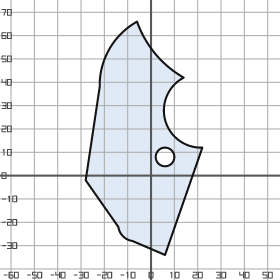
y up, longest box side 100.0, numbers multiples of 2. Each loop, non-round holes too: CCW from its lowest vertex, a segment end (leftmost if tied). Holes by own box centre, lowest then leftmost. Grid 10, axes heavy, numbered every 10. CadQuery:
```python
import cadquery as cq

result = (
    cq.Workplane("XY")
    .moveTo(6.0, -34.0)
    .lineTo(22.0, 12.0)
    .threePointArc((6.0, 24.0), (14.0, 42.0))
    .threePointArc((2.0, 52.0), (-6.0, 66.0))
    .threePointArc((-18.0, 54.0), (-22.0, 38.0))
    .lineTo(-28.0, -2.0)
    .lineTo(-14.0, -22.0)
    .threePointArc((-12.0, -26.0), (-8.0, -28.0))
    .close()
    .moveTo(6.0, 8.0)
    .circle(4.0)
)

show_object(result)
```